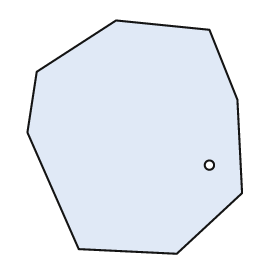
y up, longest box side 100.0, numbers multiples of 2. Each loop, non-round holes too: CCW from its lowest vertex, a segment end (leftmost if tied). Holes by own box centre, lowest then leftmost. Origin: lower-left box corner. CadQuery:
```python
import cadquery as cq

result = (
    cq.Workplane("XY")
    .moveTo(64.0, 0.0)
    .lineTo(92.0, 26.0)
    .lineTo(90.0, 66.0)
    .lineTo(78.0, 96.0)
    .lineTo(38.0, 100.0)
    .lineTo(4.0, 78.0)
    .lineTo(0.0, 52.0)
    .lineTo(22.0, 2.0)
    .close()
    .moveTo(78.0, 38.0)
    .circle(2.0)
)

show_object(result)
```